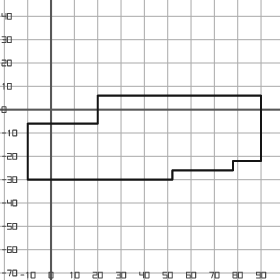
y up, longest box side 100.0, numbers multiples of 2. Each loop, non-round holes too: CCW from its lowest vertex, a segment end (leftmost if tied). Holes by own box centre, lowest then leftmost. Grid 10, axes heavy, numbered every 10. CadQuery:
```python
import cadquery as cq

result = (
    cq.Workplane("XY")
    .moveTo(-10.0, -30.0)
    .lineTo(52.0, -30.0)
    .lineTo(52.0, -26.0)
    .lineTo(78.0, -26.0)
    .lineTo(78.0, -22.0)
    .lineTo(90.0, -22.0)
    .lineTo(90.0, 6.0)
    .lineTo(20.0, 6.0)
    .lineTo(20.0, -6.0)
    .lineTo(-10.0, -6.0)
    .close()
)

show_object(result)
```